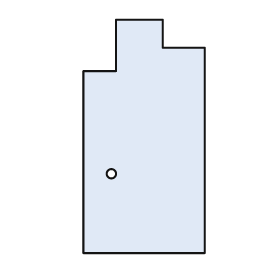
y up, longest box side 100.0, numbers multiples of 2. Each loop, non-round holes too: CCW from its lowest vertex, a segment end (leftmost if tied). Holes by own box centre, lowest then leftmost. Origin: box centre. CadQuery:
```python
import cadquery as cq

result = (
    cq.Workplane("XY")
    .moveTo(-26.0, -50.0)
    .lineTo(26.0, -50.0)
    .lineTo(26.0, 38.0)
    .lineTo(8.0, 38.0)
    .lineTo(8.0, 50.0)
    .lineTo(-12.0, 50.0)
    .lineTo(-12.0, 28.0)
    .lineTo(-26.0, 28.0)
    .close()
    .moveTo(-14.0, -16.0)
    .circle(2.0)
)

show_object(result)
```